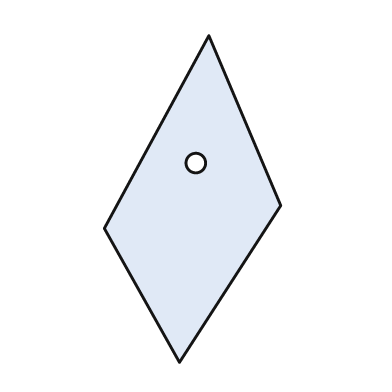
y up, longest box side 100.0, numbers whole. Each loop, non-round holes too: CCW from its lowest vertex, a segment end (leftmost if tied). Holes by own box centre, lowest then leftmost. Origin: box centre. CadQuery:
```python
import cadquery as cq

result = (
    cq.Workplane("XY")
    .moveTo(-4.0, -50.0)
    .lineTo(27.0, -2.0)
    .lineTo(5.0, 50.0)
    .lineTo(-27.0, -9.0)
    .close()
    .moveTo(1.0, 11.0)
    .circle(3.0)
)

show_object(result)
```